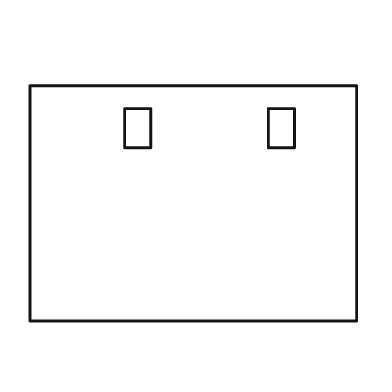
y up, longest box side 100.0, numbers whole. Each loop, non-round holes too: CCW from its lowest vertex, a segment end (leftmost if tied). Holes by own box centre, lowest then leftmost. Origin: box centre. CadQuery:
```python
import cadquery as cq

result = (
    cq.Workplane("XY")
    .moveTo(-50.0, -36.0)
    .lineTo(50.0, -36.0)
    .lineTo(50.0, 36.0)
    .lineTo(-50.0, 36.0)
    .close()
    .moveTo(-21.0, 17.0)
    .lineTo(-13.0, 17.0)
    .lineTo(-13.0, 29.0)
    .lineTo(-21.0, 29.0)
    .close()
    .moveTo(23.0, 17.0)
    .lineTo(31.0, 17.0)
    .lineTo(31.0, 29.0)
    .lineTo(23.0, 29.0)
    .close()
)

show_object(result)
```